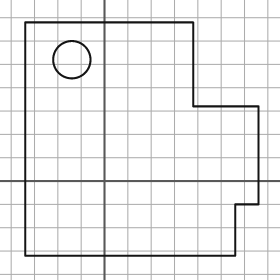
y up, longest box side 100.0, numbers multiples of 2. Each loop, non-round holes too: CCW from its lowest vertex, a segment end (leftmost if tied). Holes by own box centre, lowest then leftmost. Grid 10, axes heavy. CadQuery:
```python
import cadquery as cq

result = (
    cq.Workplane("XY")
    .moveTo(-34.0, -32.0)
    .lineTo(56.0, -32.0)
    .lineTo(56.0, -10.0)
    .lineTo(66.0, -10.0)
    .lineTo(66.0, 32.0)
    .lineTo(38.0, 32.0)
    .lineTo(38.0, 68.0)
    .lineTo(-34.0, 68.0)
    .close()
    .moveTo(-14.0, 52.0)
    .circle(8.0)
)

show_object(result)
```